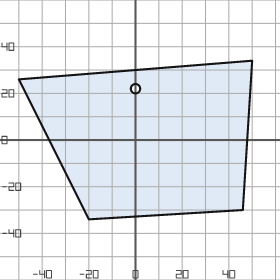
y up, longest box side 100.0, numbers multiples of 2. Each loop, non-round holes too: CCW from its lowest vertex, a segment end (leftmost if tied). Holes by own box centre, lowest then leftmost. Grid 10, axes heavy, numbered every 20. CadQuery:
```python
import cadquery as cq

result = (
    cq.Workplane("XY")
    .moveTo(-20.0, -34.0)
    .lineTo(46.0, -30.0)
    .lineTo(50.0, 34.0)
    .lineTo(-50.0, 26.0)
    .close()
    .moveTo(0.0, 22.0)
    .circle(2.0)
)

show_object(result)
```